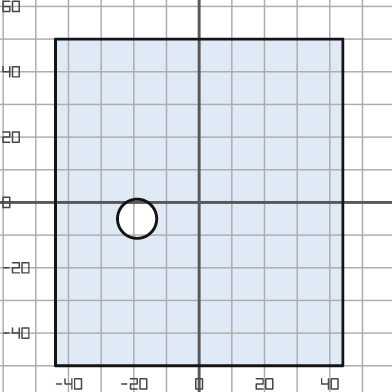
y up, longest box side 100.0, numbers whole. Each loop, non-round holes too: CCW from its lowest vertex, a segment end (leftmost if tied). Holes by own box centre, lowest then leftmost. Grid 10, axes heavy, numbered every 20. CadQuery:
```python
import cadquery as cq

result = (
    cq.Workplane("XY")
    .moveTo(-44.0, -50.0)
    .lineTo(44.0, -50.0)
    .lineTo(44.0, 50.0)
    .lineTo(-44.0, 50.0)
    .close()
    .moveTo(-19.0, -5.0)
    .circle(6.0)
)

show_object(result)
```